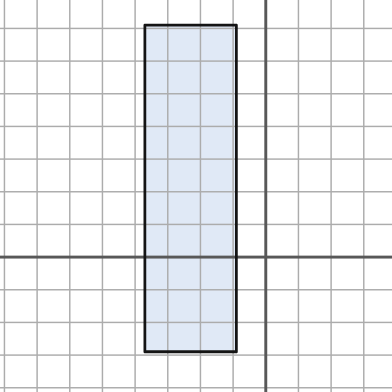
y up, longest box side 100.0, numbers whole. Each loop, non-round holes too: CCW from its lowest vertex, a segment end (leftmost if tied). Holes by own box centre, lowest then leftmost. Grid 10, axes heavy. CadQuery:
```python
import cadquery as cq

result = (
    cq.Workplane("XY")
    .moveTo(-37.0, -29.0)
    .lineTo(-9.0, -29.0)
    .lineTo(-9.0, 71.0)
    .lineTo(-37.0, 71.0)
    .close()
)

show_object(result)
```